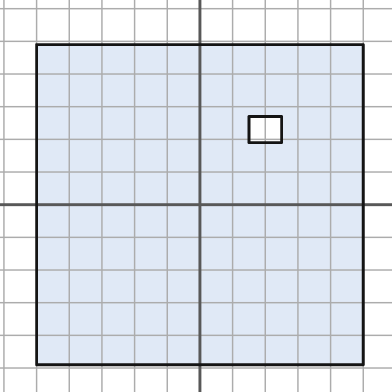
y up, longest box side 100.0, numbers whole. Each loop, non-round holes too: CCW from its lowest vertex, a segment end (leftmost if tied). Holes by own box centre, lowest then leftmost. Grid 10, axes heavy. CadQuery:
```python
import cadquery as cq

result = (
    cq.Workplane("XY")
    .moveTo(-50.0, -49.0)
    .lineTo(50.0, -49.0)
    .lineTo(50.0, 49.0)
    .lineTo(-50.0, 49.0)
    .close()
    .moveTo(15.0, 19.0)
    .lineTo(25.0, 19.0)
    .lineTo(25.0, 27.0)
    .lineTo(15.0, 27.0)
    .close()
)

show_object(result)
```